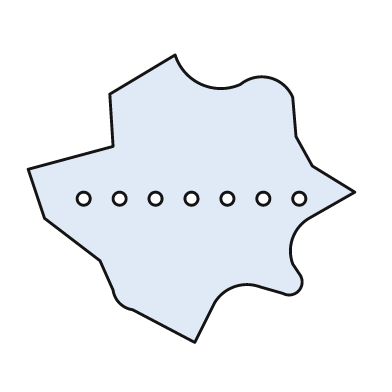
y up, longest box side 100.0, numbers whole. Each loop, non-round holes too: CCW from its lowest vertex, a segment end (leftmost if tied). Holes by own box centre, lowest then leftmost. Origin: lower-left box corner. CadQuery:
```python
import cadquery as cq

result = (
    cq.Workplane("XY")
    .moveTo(51.0, 0.0)
    .lineTo(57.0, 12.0)
    .threePointArc((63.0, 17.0), (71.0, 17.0))
    .lineTo(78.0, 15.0)
    .threePointArc((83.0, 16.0), (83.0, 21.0))
    .lineTo(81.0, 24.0)
    .threePointArc((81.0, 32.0), (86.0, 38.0))
    .lineTo(100.0, 46.0)
    .lineTo(87.0, 54.0)
    .lineTo(82.0, 63.0)
    .lineTo(81.0, 75.0)
    .threePointArc((74.0, 81.0), (65.0, 79.0))
    .threePointArc((53.0, 79.0), (45.0, 88.0))
    .lineTo(25.0, 76.0)
    .lineTo(26.0, 60.0)
    .lineTo(0.0, 53.0)
    .lineTo(5.0, 38.0)
    .lineTo(22.0, 25.0)
    .lineTo(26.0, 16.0)
    .threePointArc((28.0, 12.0), (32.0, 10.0))
    .close()
    .moveTo(17.0, 44.0)
    .circle(2.0)
    .moveTo(28.0, 44.0)
    .circle(2.0)
    .moveTo(39.0, 44.0)
    .circle(2.0)
    .moveTo(50.0, 44.0)
    .circle(2.0)
    .moveTo(61.0, 44.0)
    .circle(2.0)
    .moveTo(72.0, 44.0)
    .circle(2.0)
    .moveTo(83.0, 44.0)
    .circle(2.0)
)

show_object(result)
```